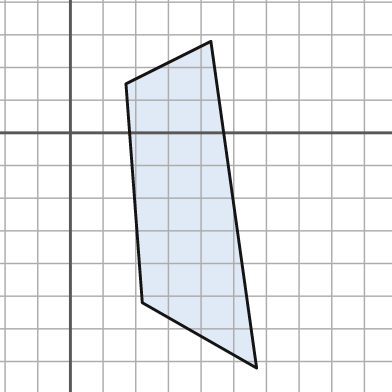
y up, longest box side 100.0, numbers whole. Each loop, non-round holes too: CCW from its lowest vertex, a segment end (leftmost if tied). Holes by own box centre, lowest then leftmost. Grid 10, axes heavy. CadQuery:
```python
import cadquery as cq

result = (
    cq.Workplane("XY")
    .moveTo(57.0, -72.0)
    .lineTo(43.0, 28.0)
    .lineTo(17.0, 15.0)
    .lineTo(22.0, -52.0)
    .close()
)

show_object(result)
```